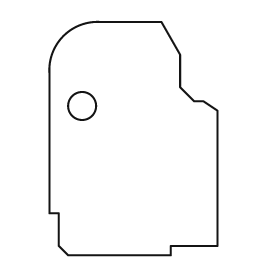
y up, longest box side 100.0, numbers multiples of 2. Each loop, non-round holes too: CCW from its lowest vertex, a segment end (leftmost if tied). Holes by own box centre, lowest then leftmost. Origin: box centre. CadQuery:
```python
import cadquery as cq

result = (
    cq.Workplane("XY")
    .moveTo(-28.0, -50.0)
    .lineTo(16.0, -50.0)
    .lineTo(16.0, -46.0)
    .lineTo(36.0, -46.0)
    .lineTo(36.0, 12.0)
    .lineTo(30.0, 16.0)
    .lineTo(26.0, 16.0)
    .lineTo(20.0, 22.0)
    .lineTo(20.0, 36.0)
    .lineTo(12.0, 50.0)
    .lineTo(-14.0, 50.0)
    .threePointArc((-30.0, 44.0), (-36.0, 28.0))
    .lineTo(-36.0, -32.0)
    .lineTo(-32.0, -32.0)
    .lineTo(-32.0, -46.0)
    .close()
    .moveTo(-22.0, 14.0)
    .circle(6.0)
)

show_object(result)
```